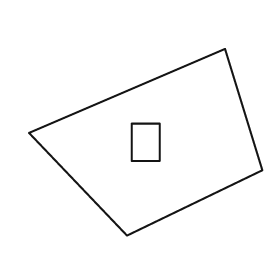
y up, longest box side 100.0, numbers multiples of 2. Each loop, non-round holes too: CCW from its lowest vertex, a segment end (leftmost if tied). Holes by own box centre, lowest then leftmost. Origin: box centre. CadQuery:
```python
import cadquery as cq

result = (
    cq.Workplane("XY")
    .moveTo(-8.0, -40.0)
    .lineTo(50.0, -12.0)
    .lineTo(34.0, 40.0)
    .lineTo(-50.0, 4.0)
    .close()
    .moveTo(-6.0, -8.0)
    .lineTo(6.0, -8.0)
    .lineTo(6.0, 8.0)
    .lineTo(-6.0, 8.0)
    .close()
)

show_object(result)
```